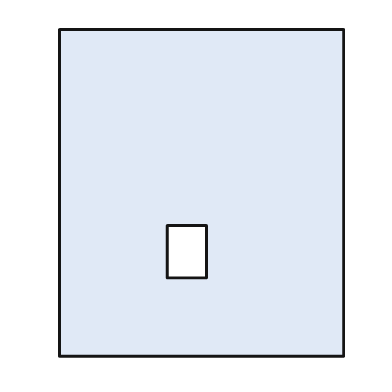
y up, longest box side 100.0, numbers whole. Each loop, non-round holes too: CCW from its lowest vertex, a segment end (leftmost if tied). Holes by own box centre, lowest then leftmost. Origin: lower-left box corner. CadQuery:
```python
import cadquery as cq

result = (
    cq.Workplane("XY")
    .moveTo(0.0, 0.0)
    .lineTo(87.0, 0.0)
    .lineTo(87.0, 100.0)
    .lineTo(0.0, 100.0)
    .close()
    .moveTo(33.0, 24.0)
    .lineTo(45.0, 24.0)
    .lineTo(45.0, 40.0)
    .lineTo(33.0, 40.0)
    .close()
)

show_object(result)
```